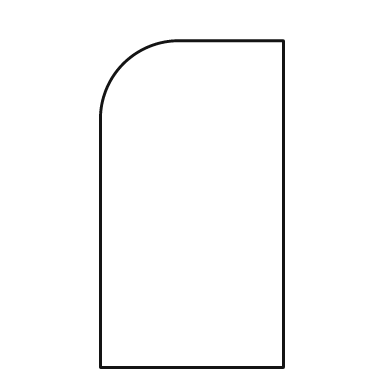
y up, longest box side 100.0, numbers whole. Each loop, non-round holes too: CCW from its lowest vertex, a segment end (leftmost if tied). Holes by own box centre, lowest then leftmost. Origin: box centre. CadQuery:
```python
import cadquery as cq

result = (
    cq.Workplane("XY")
    .moveTo(-28.0, -50.0)
    .lineTo(28.0, -50.0)
    .lineTo(28.0, 50.0)
    .lineTo(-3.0, 50.0)
    .threePointArc((-21.0, 43.0), (-28.0, 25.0))
    .close()
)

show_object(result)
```